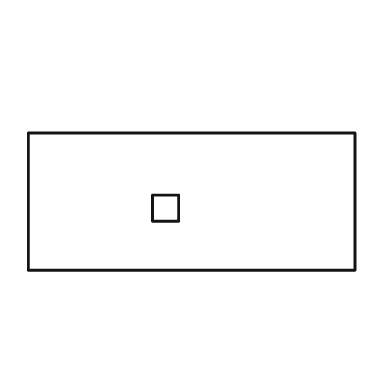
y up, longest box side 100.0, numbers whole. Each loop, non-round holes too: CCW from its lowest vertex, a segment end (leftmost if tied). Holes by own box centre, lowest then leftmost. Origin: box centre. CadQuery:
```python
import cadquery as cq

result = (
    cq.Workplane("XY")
    .moveTo(-50.0, -21.0)
    .lineTo(50.0, -21.0)
    .lineTo(50.0, 21.0)
    .lineTo(-50.0, 21.0)
    .close()
    .moveTo(-12.0, -6.0)
    .lineTo(-4.0, -6.0)
    .lineTo(-4.0, 2.0)
    .lineTo(-12.0, 2.0)
    .close()
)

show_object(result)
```